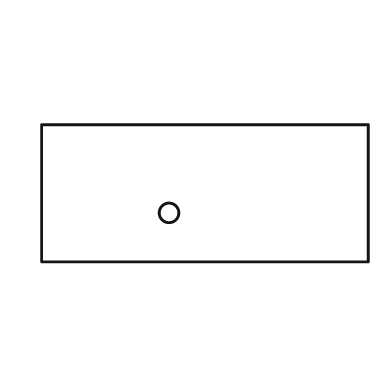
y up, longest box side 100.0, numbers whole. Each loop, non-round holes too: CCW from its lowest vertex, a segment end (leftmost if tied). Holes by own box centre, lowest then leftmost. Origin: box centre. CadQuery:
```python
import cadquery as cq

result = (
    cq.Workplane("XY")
    .moveTo(-50.0, -21.0)
    .lineTo(50.0, -21.0)
    .lineTo(50.0, 21.0)
    .lineTo(-50.0, 21.0)
    .close()
    .moveTo(-11.0, -6.0)
    .circle(3.0)
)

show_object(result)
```